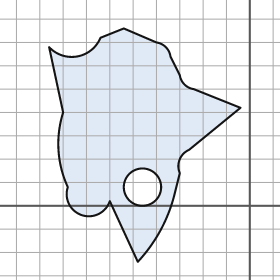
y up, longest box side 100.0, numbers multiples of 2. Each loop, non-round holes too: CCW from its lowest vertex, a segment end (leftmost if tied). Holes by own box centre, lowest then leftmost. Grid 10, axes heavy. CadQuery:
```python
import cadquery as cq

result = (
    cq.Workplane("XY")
    .moveTo(-48.0, -24.0)
    .threePointArc((-38.0, -10.0), (-32.0, 6.0))
    .lineTo(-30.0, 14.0)
    .threePointArc((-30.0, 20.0), (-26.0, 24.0))
    .lineTo(-4.0, 42.0)
    .lineTo(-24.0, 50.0)
    .threePointArc((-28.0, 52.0), (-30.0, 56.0))
    .lineTo(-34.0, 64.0)
    .threePointArc((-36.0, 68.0), (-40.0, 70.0))
    .lineTo(-54.0, 76.0)
    .lineTo(-64.0, 72.0)
    .threePointArc((-74.0, 64.0), (-86.0, 68.0))
    .lineTo(-80.0, 40.0)
    .threePointArc((-82.0, 24.0), (-78.0, 8.0))
    .threePointArc((-72.0, -4.0), (-60.0, 2.0))
    .close()
    .moveTo(-46.0, 8.0)
    .circle(8.0)
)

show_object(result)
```